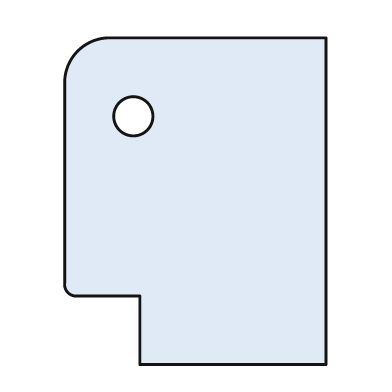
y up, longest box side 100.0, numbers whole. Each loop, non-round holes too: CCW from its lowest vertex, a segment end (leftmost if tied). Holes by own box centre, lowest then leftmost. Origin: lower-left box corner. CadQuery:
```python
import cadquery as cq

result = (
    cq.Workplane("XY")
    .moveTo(23.0, 0.0)
    .lineTo(80.0, 0.0)
    .lineTo(80.0, 100.0)
    .lineTo(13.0, 100.0)
    .threePointArc((4.0, 96.0), (0.0, 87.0))
    .lineTo(0.0, 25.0)
    .threePointArc((1.0, 22.0), (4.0, 21.0))
    .lineTo(23.0, 21.0)
    .close()
    .moveTo(21.0, 76.0)
    .circle(6.0)
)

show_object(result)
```